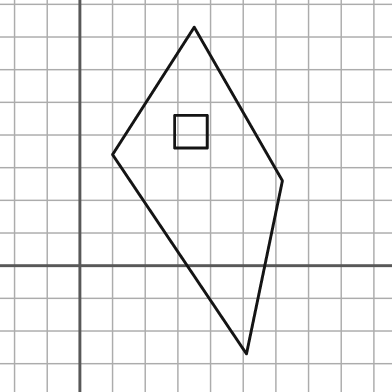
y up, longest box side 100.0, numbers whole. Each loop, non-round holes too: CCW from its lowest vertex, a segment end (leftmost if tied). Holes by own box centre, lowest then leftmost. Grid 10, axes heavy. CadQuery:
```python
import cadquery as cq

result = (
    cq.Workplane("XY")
    .moveTo(51.0, -27.0)
    .lineTo(62.0, 26.0)
    .lineTo(35.0, 73.0)
    .lineTo(10.0, 34.0)
    .close()
    .moveTo(29.0, 36.0)
    .lineTo(39.0, 36.0)
    .lineTo(39.0, 46.0)
    .lineTo(29.0, 46.0)
    .close()
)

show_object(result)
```